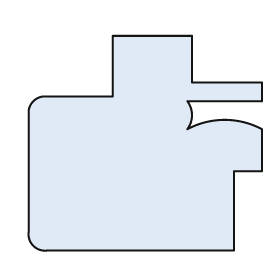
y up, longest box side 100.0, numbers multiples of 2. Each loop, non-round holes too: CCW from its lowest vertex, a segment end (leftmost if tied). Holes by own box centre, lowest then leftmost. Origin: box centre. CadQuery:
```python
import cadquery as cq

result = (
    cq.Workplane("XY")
    .moveTo(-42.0, -46.0)
    .lineTo(38.0, -46.0)
    .lineTo(38.0, -12.0)
    .lineTo(50.0, -12.0)
    .lineTo(50.0, 6.0)
    .threePointArc((34.0, 10.0), (18.0, 6.0))
    .threePointArc((20.0, 12.0), (18.0, 18.0))
    .lineTo(50.0, 18.0)
    .lineTo(50.0, 26.0)
    .lineTo(20.0, 26.0)
    .lineTo(20.0, 46.0)
    .lineTo(-14.0, 46.0)
    .lineTo(-14.0, 20.0)
    .lineTo(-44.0, 20.0)
    .threePointArc((-48.0, 18.0), (-50.0, 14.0))
    .lineTo(-50.0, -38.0)
    .threePointArc((-48.0, -44.0), (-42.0, -46.0))
    .close()
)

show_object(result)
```